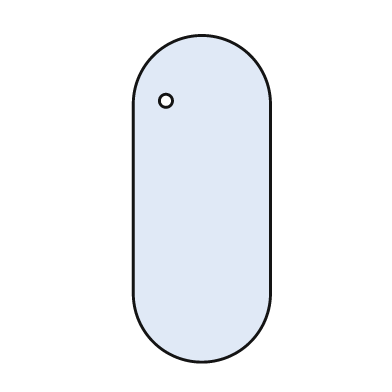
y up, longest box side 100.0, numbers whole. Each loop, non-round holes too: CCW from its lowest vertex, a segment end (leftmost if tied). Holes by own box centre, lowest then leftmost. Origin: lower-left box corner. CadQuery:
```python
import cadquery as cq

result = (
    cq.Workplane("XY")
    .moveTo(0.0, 21.0)
    .threePointArc((21.0, 0.0), (42.0, 21.0))
    .lineTo(42.0, 79.0)
    .threePointArc((21.0, 100.0), (0.0, 79.0))
    .close()
    .moveTo(10.0, 80.0)
    .circle(2.0)
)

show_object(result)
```